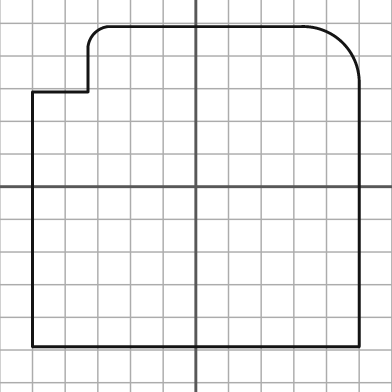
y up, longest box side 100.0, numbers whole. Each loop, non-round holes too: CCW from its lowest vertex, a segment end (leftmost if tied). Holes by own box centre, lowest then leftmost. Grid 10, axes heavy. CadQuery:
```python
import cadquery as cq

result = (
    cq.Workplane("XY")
    .moveTo(-50.0, -49.0)
    .lineTo(50.0, -49.0)
    .lineTo(50.0, 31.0)
    .threePointArc((45.0, 44.0), (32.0, 49.0))
    .lineTo(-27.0, 49.0)
    .threePointArc((-31.0, 47.0), (-33.0, 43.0))
    .lineTo(-33.0, 29.0)
    .lineTo(-50.0, 29.0)
    .close()
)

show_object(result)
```